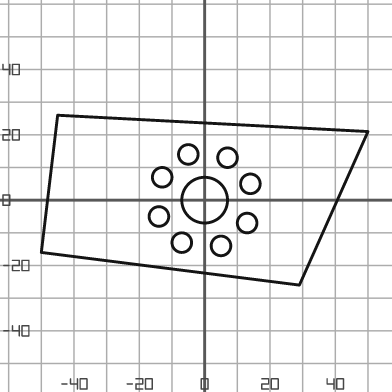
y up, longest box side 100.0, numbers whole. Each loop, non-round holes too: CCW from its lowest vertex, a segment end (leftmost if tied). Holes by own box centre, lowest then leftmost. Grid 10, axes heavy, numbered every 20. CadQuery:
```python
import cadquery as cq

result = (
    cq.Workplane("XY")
    .moveTo(29.0, -26.0)
    .lineTo(50.0, 21.0)
    .lineTo(-45.0, 26.0)
    .lineTo(-50.0, -16.0)
    .close()
    .moveTo(5.0, -14.0)
    .circle(3.0)
    .moveTo(-7.0, -13.0)
    .circle(3.0)
    .moveTo(13.0, -7.0)
    .circle(3.0)
    .moveTo(-14.0, -5.0)
    .circle(3.0)
    .moveTo(0.0, 0.0)
    .circle(7.0)
    .moveTo(14.0, 5.0)
    .circle(3.0)
    .moveTo(-13.0, 7.0)
    .circle(3.0)
    .moveTo(7.0, 13.0)
    .circle(3.0)
    .moveTo(-5.0, 14.0)
    .circle(3.0)
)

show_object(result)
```